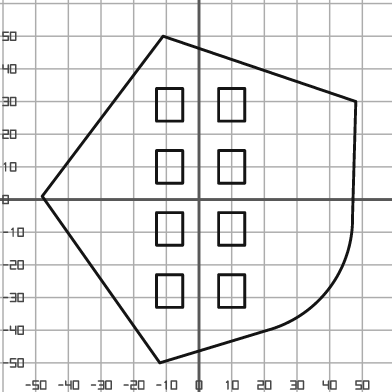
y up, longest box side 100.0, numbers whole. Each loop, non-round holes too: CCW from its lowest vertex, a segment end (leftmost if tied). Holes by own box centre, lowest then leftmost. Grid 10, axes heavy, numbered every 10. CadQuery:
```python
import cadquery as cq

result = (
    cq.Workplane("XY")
    .moveTo(-12.0, -50.0)
    .lineTo(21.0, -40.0)
    .threePointArc((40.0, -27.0), (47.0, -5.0))
    .lineTo(48.0, 30.0)
    .lineTo(-11.0, 50.0)
    .lineTo(-48.0, 1.0)
    .close()
    .moveTo(-13.0, -33.0)
    .lineTo(-5.0, -33.0)
    .lineTo(-5.0, -23.0)
    .lineTo(-13.0, -23.0)
    .close()
    .moveTo(6.0, -33.0)
    .lineTo(14.0, -33.0)
    .lineTo(14.0, -23.0)
    .lineTo(6.0, -23.0)
    .close()
    .moveTo(-13.0, -14.0)
    .lineTo(-5.0, -14.0)
    .lineTo(-5.0, -4.0)
    .lineTo(-13.0, -4.0)
    .close()
    .moveTo(6.0, -14.0)
    .lineTo(14.0, -14.0)
    .lineTo(14.0, -4.0)
    .lineTo(6.0, -4.0)
    .close()
    .moveTo(-13.0, 5.0)
    .lineTo(-5.0, 5.0)
    .lineTo(-5.0, 15.0)
    .lineTo(-13.0, 15.0)
    .close()
    .moveTo(6.0, 5.0)
    .lineTo(14.0, 5.0)
    .lineTo(14.0, 15.0)
    .lineTo(6.0, 15.0)
    .close()
    .moveTo(-13.0, 24.0)
    .lineTo(-5.0, 24.0)
    .lineTo(-5.0, 34.0)
    .lineTo(-13.0, 34.0)
    .close()
    .moveTo(6.0, 24.0)
    .lineTo(14.0, 24.0)
    .lineTo(14.0, 34.0)
    .lineTo(6.0, 34.0)
    .close()
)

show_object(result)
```